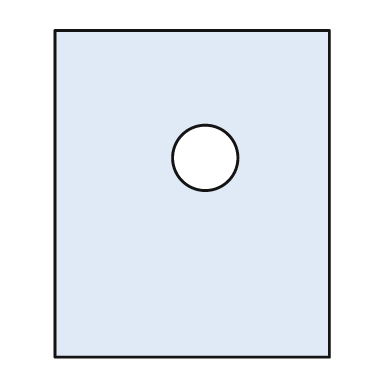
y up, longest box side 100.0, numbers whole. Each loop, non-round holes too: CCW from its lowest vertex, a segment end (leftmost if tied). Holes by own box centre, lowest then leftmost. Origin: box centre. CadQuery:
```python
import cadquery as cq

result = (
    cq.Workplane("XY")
    .moveTo(-42.0, -50.0)
    .lineTo(42.0, -50.0)
    .lineTo(42.0, 50.0)
    .lineTo(-42.0, 50.0)
    .close()
    .moveTo(4.0, 11.0)
    .circle(10.0)
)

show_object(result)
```